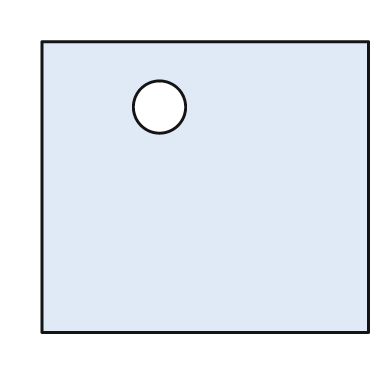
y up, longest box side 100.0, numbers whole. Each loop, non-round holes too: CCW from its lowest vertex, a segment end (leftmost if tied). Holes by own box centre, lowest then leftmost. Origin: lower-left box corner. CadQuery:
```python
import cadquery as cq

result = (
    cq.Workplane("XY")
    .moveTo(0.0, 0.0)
    .lineTo(100.0, 0.0)
    .lineTo(100.0, 89.0)
    .lineTo(0.0, 89.0)
    .close()
    .moveTo(36.0, 69.0)
    .circle(8.0)
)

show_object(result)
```